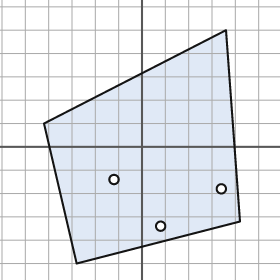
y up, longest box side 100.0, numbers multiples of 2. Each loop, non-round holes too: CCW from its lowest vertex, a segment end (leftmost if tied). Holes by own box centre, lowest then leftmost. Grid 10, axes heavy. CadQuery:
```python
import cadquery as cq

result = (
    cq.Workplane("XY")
    .moveTo(-28.0, -50.0)
    .lineTo(42.0, -32.0)
    .lineTo(36.0, 50.0)
    .lineTo(-42.0, 10.0)
    .close()
    .moveTo(8.0, -34.0)
    .circle(2.0)
    .moveTo(34.0, -18.0)
    .circle(2.0)
    .moveTo(-12.0, -14.0)
    .circle(2.0)
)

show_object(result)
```